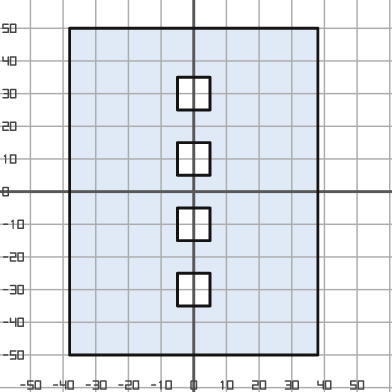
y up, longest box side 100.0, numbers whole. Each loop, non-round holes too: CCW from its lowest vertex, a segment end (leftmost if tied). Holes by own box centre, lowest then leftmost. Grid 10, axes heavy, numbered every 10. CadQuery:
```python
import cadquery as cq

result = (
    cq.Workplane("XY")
    .moveTo(-38.0, -50.0)
    .lineTo(38.0, -50.0)
    .lineTo(38.0, 50.0)
    .lineTo(-38.0, 50.0)
    .close()
    .moveTo(-5.0, -35.0)
    .lineTo(5.0, -35.0)
    .lineTo(5.0, -25.0)
    .lineTo(-5.0, -25.0)
    .close()
    .moveTo(-5.0, -15.0)
    .lineTo(5.0, -15.0)
    .lineTo(5.0, -5.0)
    .lineTo(-5.0, -5.0)
    .close()
    .moveTo(-5.0, 5.0)
    .lineTo(5.0, 5.0)
    .lineTo(5.0, 15.0)
    .lineTo(-5.0, 15.0)
    .close()
    .moveTo(-5.0, 25.0)
    .lineTo(5.0, 25.0)
    .lineTo(5.0, 35.0)
    .lineTo(-5.0, 35.0)
    .close()
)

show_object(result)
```